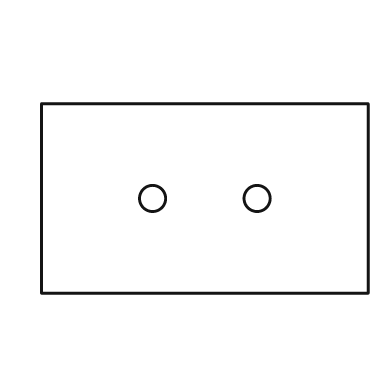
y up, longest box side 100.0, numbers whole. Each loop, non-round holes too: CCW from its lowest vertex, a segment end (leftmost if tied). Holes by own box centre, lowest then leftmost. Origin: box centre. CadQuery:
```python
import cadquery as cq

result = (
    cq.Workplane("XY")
    .moveTo(-50.0, -29.0)
    .lineTo(50.0, -29.0)
    .lineTo(50.0, 29.0)
    .lineTo(-50.0, 29.0)
    .close()
    .moveTo(-16.0, 0.0)
    .circle(4.0)
    .moveTo(16.0, 0.0)
    .circle(4.0)
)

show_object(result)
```